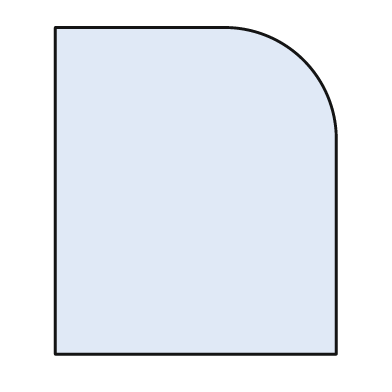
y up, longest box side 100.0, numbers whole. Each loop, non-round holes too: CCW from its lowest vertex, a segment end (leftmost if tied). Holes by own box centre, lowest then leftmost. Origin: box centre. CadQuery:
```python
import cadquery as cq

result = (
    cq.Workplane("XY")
    .moveTo(-43.0, -50.0)
    .lineTo(43.0, -50.0)
    .lineTo(43.0, 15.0)
    .threePointArc((33.0, 40.0), (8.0, 50.0))
    .lineTo(-43.0, 50.0)
    .close()
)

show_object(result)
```